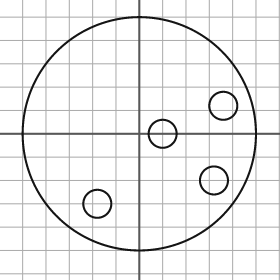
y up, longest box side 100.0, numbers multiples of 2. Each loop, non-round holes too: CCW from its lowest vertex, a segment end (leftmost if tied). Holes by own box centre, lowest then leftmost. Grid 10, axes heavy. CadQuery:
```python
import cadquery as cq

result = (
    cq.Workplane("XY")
    .moveTo(0.0, 0.0)
    .circle(50.0)
    .moveTo(-18.0, -30.0)
    .circle(6.0)
    .moveTo(32.0, -20.0)
    .circle(6.0)
    .moveTo(10.0, 0.0)
    .circle(6.0)
    .moveTo(36.0, 12.0)
    .circle(6.0)
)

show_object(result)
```